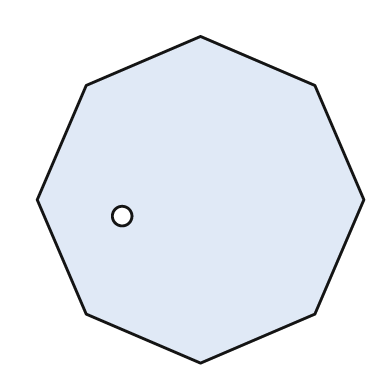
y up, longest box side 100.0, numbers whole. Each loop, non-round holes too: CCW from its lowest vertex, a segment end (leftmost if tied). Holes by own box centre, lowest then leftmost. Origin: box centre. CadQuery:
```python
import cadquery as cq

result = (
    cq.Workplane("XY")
    .moveTo(0.0, -50.0)
    .lineTo(35.0, -35.0)
    .lineTo(50.0, 0.0)
    .lineTo(35.0, 35.0)
    .lineTo(0.0, 50.0)
    .lineTo(-35.0, 35.0)
    .lineTo(-50.0, 0.0)
    .lineTo(-35.0, -35.0)
    .close()
    .moveTo(-24.0, -5.0)
    .circle(3.0)
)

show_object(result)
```